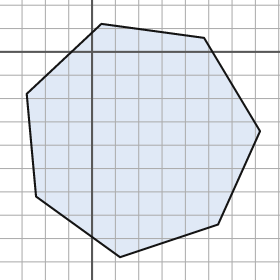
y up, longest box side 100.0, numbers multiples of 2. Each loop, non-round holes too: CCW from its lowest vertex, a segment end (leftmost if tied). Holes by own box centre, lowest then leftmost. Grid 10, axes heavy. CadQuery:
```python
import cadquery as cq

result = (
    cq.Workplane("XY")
    .moveTo(12.0, -88.0)
    .lineTo(54.0, -74.0)
    .lineTo(72.0, -34.0)
    .lineTo(48.0, 6.0)
    .lineTo(4.0, 12.0)
    .lineTo(-28.0, -18.0)
    .lineTo(-24.0, -62.0)
    .close()
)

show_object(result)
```